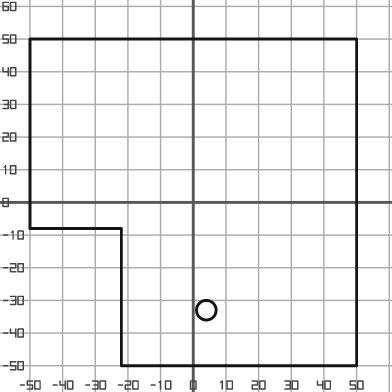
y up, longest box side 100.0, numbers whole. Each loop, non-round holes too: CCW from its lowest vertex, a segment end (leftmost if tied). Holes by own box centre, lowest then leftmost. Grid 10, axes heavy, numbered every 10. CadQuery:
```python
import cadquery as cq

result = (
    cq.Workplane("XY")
    .moveTo(-22.0, -50.0)
    .lineTo(50.0, -50.0)
    .lineTo(50.0, 50.0)
    .lineTo(-50.0, 50.0)
    .lineTo(-50.0, -8.0)
    .lineTo(-22.0, -8.0)
    .close()
    .moveTo(4.0, -33.0)
    .circle(3.0)
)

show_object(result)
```